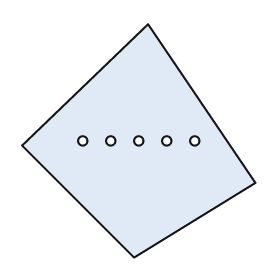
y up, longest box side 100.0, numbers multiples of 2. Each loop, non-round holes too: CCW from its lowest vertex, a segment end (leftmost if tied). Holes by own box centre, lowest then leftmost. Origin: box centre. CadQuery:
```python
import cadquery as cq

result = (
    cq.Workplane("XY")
    .moveTo(-2.0, -50.0)
    .lineTo(50.0, -18.0)
    .lineTo(4.0, 50.0)
    .lineTo(-50.0, -2.0)
    .close()
    .moveTo(-24.0, 0.0)
    .circle(2.0)
    .moveTo(-12.0, 0.0)
    .circle(2.0)
    .moveTo(0.0, 0.0)
    .circle(2.0)
    .moveTo(12.0, 0.0)
    .circle(2.0)
    .moveTo(24.0, 0.0)
    .circle(2.0)
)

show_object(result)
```